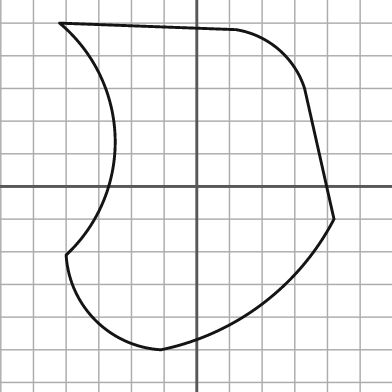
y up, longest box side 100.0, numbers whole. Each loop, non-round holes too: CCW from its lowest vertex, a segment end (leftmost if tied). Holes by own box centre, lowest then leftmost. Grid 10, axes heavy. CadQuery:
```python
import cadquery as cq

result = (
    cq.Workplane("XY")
    .moveTo(-11.0, -50.0)
    .threePointArc((20.0, -36.0), (42.0, -10.0))
    .lineTo(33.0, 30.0)
    .threePointArc((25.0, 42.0), (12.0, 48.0))
    .lineTo(-42.0, 50.0)
    .threePointArc((-25.0, 15.0), (-40.0, -21.0))
    .threePointArc((-31.0, -41.0), (-11.0, -50.0))
    .close()
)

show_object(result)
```